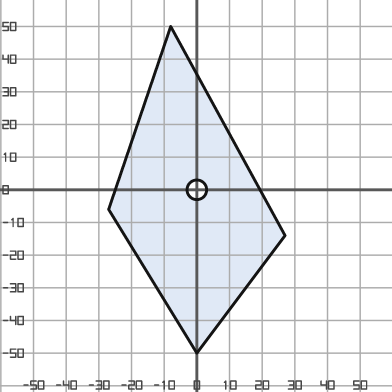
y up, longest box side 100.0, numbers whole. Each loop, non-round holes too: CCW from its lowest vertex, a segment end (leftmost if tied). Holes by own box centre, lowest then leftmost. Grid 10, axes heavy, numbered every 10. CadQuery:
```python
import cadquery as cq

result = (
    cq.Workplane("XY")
    .moveTo(0.0, -50.0)
    .lineTo(27.0, -14.0)
    .lineTo(-8.0, 50.0)
    .lineTo(-27.0, -6.0)
    .close()
    .moveTo(0.0, 0.0)
    .circle(3.0)
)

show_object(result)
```